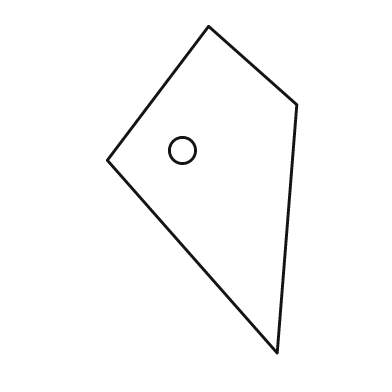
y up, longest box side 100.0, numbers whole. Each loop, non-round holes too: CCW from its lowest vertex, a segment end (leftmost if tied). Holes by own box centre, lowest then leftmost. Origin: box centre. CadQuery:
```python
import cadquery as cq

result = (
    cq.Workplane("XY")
    .moveTo(23.0, -50.0)
    .lineTo(29.0, 26.0)
    .lineTo(2.0, 50.0)
    .lineTo(-29.0, 9.0)
    .close()
    .moveTo(-6.0, 12.0)
    .circle(4.0)
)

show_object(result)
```